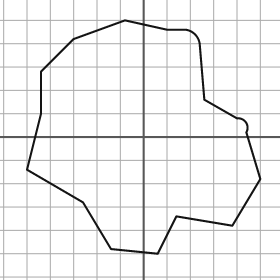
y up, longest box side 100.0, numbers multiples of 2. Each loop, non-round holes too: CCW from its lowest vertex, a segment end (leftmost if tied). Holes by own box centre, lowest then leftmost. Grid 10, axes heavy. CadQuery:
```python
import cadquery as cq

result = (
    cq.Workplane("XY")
    .moveTo(6.0, -50.0)
    .lineTo(14.0, -34.0)
    .lineTo(38.0, -38.0)
    .lineTo(50.0, -18.0)
    .lineTo(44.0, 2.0)
    .threePointArc((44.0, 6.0), (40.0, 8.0))
    .lineTo(26.0, 16.0)
    .lineTo(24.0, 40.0)
    .threePointArc((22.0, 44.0), (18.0, 46.0))
    .lineTo(10.0, 46.0)
    .lineTo(-8.0, 50.0)
    .lineTo(-30.0, 42.0)
    .lineTo(-44.0, 28.0)
    .lineTo(-44.0, 10.0)
    .lineTo(-50.0, -14.0)
    .lineTo(-26.0, -28.0)
    .lineTo(-14.0, -48.0)
    .close()
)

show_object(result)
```